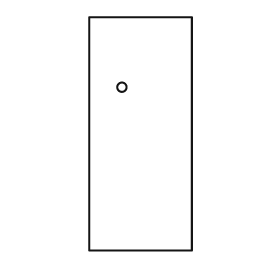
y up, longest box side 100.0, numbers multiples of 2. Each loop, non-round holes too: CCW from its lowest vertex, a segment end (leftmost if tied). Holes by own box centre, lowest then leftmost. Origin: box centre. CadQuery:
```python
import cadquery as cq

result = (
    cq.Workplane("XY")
    .moveTo(-22.0, -50.0)
    .lineTo(22.0, -50.0)
    .lineTo(22.0, 50.0)
    .lineTo(-22.0, 50.0)
    .close()
    .moveTo(-8.0, 20.0)
    .circle(2.0)
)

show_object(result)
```